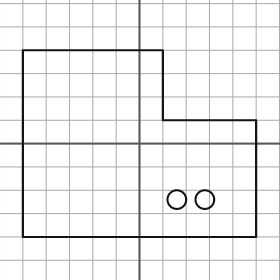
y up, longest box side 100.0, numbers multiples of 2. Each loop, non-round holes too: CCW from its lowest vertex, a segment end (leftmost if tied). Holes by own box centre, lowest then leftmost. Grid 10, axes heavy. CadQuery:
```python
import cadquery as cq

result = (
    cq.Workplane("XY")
    .moveTo(-50.0, -40.0)
    .lineTo(50.0, -40.0)
    .lineTo(50.0, 10.0)
    .lineTo(10.0, 10.0)
    .lineTo(10.0, 40.0)
    .lineTo(-50.0, 40.0)
    .close()
    .moveTo(16.0, -24.0)
    .circle(4.0)
    .moveTo(28.0, -24.0)
    .circle(4.0)
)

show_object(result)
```